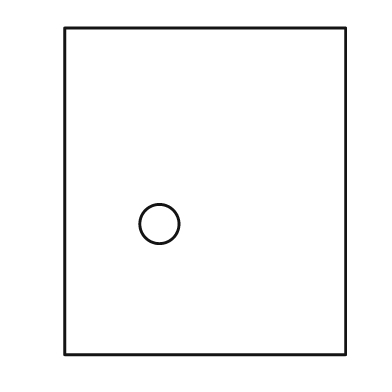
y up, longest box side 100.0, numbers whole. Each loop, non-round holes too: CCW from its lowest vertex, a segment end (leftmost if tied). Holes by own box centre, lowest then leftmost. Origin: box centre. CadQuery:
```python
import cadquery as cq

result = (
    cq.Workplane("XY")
    .moveTo(-43.0, -50.0)
    .lineTo(43.0, -50.0)
    .lineTo(43.0, 50.0)
    .lineTo(-43.0, 50.0)
    .close()
    .moveTo(-14.0, -10.0)
    .circle(6.0)
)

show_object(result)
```